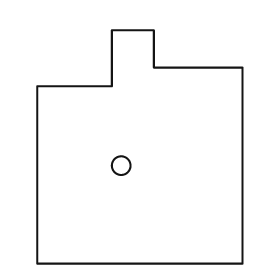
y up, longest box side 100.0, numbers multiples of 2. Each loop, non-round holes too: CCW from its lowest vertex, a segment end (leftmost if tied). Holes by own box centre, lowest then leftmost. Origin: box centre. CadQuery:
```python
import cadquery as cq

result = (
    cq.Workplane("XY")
    .moveTo(-44.0, -50.0)
    .lineTo(44.0, -50.0)
    .lineTo(44.0, 34.0)
    .lineTo(6.0, 34.0)
    .lineTo(6.0, 50.0)
    .lineTo(-12.0, 50.0)
    .lineTo(-12.0, 26.0)
    .lineTo(-44.0, 26.0)
    .close()
    .moveTo(-8.0, -8.0)
    .circle(4.0)
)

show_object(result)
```